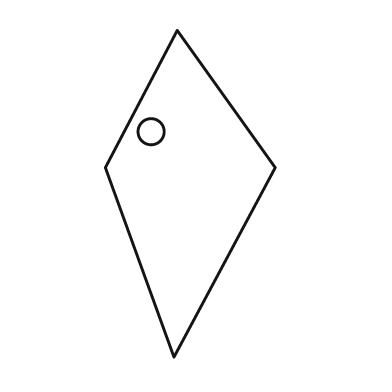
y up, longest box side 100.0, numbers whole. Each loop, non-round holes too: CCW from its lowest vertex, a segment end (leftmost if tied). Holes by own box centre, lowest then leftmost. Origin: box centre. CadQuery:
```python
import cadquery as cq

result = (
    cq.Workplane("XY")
    .moveTo(-5.0, -50.0)
    .lineTo(26.0, 8.0)
    .lineTo(-4.0, 50.0)
    .lineTo(-26.0, 8.0)
    .close()
    .moveTo(-12.0, 19.0)
    .circle(4.0)
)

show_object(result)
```